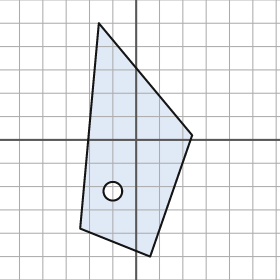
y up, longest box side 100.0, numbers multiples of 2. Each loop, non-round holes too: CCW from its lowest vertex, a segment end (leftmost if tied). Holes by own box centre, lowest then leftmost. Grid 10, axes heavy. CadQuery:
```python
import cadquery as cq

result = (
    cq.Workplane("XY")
    .moveTo(6.0, -50.0)
    .lineTo(24.0, 2.0)
    .lineTo(-16.0, 50.0)
    .lineTo(-24.0, -38.0)
    .close()
    .moveTo(-10.0, -22.0)
    .circle(4.0)
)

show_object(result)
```